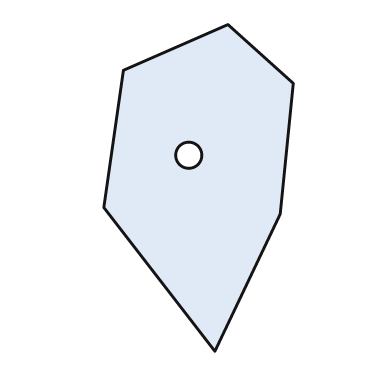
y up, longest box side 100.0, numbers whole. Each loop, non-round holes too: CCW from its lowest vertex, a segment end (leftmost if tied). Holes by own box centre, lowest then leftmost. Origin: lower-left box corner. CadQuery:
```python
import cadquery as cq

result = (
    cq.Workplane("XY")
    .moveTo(34.0, 0.0)
    .lineTo(54.0, 42.0)
    .lineTo(58.0, 82.0)
    .lineTo(38.0, 100.0)
    .lineTo(6.0, 86.0)
    .lineTo(0.0, 44.0)
    .close()
    .moveTo(26.0, 60.0)
    .circle(4.0)
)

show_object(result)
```